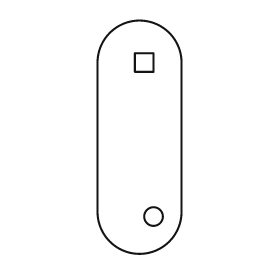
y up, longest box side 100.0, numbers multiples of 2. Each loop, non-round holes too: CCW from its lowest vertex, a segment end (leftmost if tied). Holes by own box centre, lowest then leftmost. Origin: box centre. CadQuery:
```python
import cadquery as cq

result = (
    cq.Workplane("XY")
    .moveTo(-18.0, -32.0)
    .threePointArc((0.0, -50.0), (18.0, -32.0))
    .lineTo(18.0, 32.0)
    .threePointArc((0.0, 50.0), (-18.0, 32.0))
    .close()
    .moveTo(6.0, -34.0)
    .circle(4.0)
    .moveTo(-2.0, 28.0)
    .lineTo(6.0, 28.0)
    .lineTo(6.0, 36.0)
    .lineTo(-2.0, 36.0)
    .close()
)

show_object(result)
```